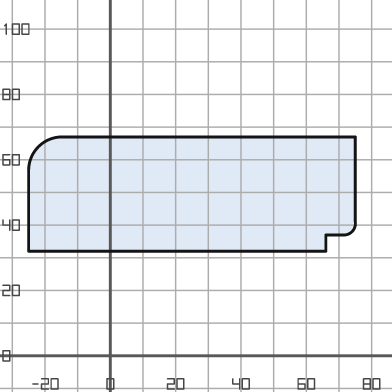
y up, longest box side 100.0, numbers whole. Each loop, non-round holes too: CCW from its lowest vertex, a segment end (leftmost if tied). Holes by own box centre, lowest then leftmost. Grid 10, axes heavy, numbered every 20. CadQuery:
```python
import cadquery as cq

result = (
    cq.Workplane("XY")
    .moveTo(-25.0, 32.0)
    .lineTo(66.0, 32.0)
    .lineTo(66.0, 37.0)
    .lineTo(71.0, 37.0)
    .threePointArc((74.0, 38.0), (75.0, 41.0))
    .lineTo(75.0, 67.0)
    .lineTo(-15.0, 67.0)
    .threePointArc((-22.0, 64.0), (-25.0, 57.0))
    .close()
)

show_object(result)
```